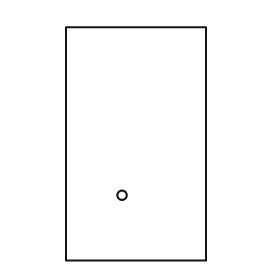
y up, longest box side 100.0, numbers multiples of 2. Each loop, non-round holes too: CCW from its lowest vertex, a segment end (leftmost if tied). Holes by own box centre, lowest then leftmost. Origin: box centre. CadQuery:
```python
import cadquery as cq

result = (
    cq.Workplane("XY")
    .moveTo(-30.0, -50.0)
    .lineTo(30.0, -50.0)
    .lineTo(30.0, 50.0)
    .lineTo(-30.0, 50.0)
    .close()
    .moveTo(-6.0, -22.0)
    .circle(2.0)
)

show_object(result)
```